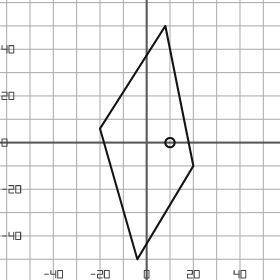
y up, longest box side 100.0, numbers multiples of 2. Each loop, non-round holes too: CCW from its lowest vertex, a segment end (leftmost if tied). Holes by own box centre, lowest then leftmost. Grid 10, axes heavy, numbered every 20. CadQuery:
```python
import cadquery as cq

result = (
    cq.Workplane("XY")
    .moveTo(-4.0, -50.0)
    .lineTo(20.0, -10.0)
    .lineTo(8.0, 50.0)
    .lineTo(-20.0, 6.0)
    .close()
    .moveTo(10.0, 0.0)
    .circle(2.0)
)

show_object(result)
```